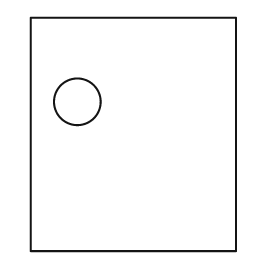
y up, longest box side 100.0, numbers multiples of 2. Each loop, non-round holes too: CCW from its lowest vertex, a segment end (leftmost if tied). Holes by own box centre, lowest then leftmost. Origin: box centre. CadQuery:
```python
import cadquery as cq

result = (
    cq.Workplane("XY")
    .moveTo(-44.0, -50.0)
    .lineTo(44.0, -50.0)
    .lineTo(44.0, 50.0)
    .lineTo(-44.0, 50.0)
    .close()
    .moveTo(-24.0, 14.0)
    .circle(10.0)
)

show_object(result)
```